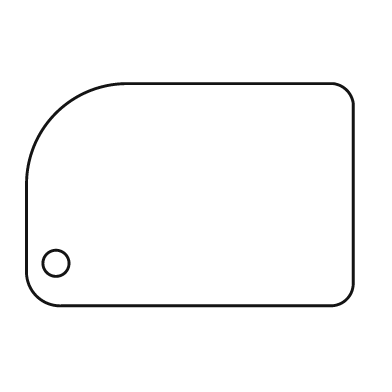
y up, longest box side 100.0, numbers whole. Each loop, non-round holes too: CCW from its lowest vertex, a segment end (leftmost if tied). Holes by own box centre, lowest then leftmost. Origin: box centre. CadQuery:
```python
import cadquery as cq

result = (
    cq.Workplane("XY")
    .moveTo(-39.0, -34.0)
    .lineTo(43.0, -34.0)
    .threePointArc((48.0, -32.0), (50.0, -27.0))
    .lineTo(50.0, 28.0)
    .threePointArc((48.0, 32.0), (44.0, 34.0))
    .lineTo(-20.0, 34.0)
    .threePointArc((-41.0, 25.0), (-50.0, 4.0))
    .lineTo(-50.0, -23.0)
    .threePointArc((-47.0, -31.0), (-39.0, -34.0))
    .close()
    .moveTo(-41.0, -21.0)
    .circle(4.0)
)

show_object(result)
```